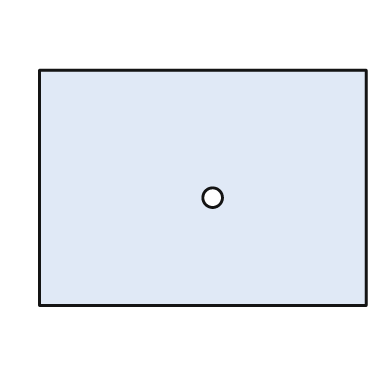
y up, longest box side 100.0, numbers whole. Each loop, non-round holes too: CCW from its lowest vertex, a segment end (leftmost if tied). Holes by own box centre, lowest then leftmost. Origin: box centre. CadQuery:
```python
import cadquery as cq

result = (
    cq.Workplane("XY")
    .moveTo(-50.0, -36.0)
    .lineTo(50.0, -36.0)
    .lineTo(50.0, 36.0)
    .lineTo(-50.0, 36.0)
    .close()
    .moveTo(3.0, -3.0)
    .circle(3.0)
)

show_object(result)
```